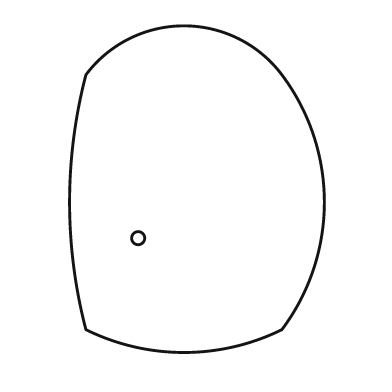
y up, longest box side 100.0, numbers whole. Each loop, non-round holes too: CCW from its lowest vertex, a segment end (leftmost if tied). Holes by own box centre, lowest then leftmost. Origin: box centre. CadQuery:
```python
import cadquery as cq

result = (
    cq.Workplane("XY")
    .moveTo(-34.0, -43.0)
    .threePointArc((-4.0, -50.0), (26.0, -43.0))
    .threePointArc((39.0, -4.0), (26.0, 35.0))
    .threePointArc((-4.0, 50.0), (-34.0, 35.0))
    .threePointArc((-39.0, -4.0), (-34.0, -43.0))
    .close()
    .moveTo(-18.0, -15.0)
    .circle(2.0)
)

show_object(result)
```